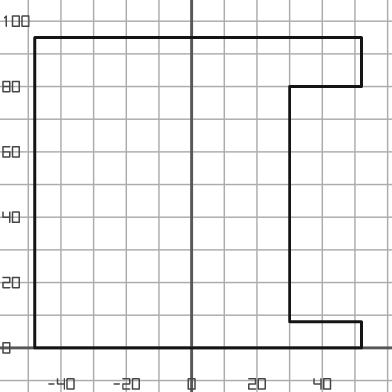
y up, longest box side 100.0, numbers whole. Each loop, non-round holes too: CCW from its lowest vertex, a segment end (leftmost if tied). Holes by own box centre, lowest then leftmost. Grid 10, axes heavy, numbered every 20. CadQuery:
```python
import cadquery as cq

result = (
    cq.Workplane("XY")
    .moveTo(-48.0, 0.0)
    .lineTo(52.0, 0.0)
    .lineTo(52.0, 8.0)
    .lineTo(30.0, 8.0)
    .lineTo(30.0, 80.0)
    .lineTo(52.0, 80.0)
    .lineTo(52.0, 95.0)
    .lineTo(-48.0, 95.0)
    .close()
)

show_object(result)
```